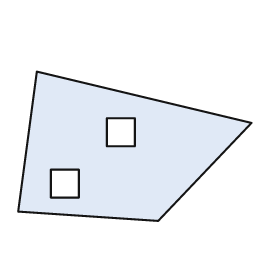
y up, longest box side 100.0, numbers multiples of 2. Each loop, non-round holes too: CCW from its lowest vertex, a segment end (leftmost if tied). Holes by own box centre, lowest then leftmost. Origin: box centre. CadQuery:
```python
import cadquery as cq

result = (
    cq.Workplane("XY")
    .moveTo(10.0, -32.0)
    .lineTo(50.0, 10.0)
    .lineTo(-42.0, 32.0)
    .lineTo(-50.0, -28.0)
    .close()
    .moveTo(-36.0, -22.0)
    .lineTo(-24.0, -22.0)
    .lineTo(-24.0, -10.0)
    .lineTo(-36.0, -10.0)
    .close()
    .moveTo(-12.0, 0.0)
    .lineTo(0.0, 0.0)
    .lineTo(0.0, 12.0)
    .lineTo(-12.0, 12.0)
    .close()
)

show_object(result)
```